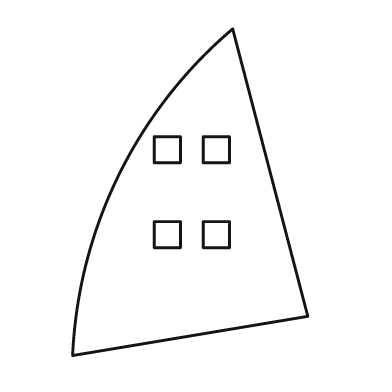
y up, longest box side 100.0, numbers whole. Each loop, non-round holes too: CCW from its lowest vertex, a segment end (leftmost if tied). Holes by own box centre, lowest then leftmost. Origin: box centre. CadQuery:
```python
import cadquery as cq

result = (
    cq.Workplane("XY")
    .moveTo(-36.0, -50.0)
    .lineTo(36.0, -38.0)
    .lineTo(13.0, 50.0)
    .threePointArc((-22.0, 5.0), (-36.0, -50.0))
    .close()
    .moveTo(-11.0, -17.0)
    .lineTo(-3.0, -17.0)
    .lineTo(-3.0, -9.0)
    .lineTo(-11.0, -9.0)
    .close()
    .moveTo(4.0, -17.0)
    .lineTo(12.0, -17.0)
    .lineTo(12.0, -9.0)
    .lineTo(4.0, -9.0)
    .close()
    .moveTo(-11.0, 9.0)
    .lineTo(-3.0, 9.0)
    .lineTo(-3.0, 17.0)
    .lineTo(-11.0, 17.0)
    .close()
    .moveTo(4.0, 9.0)
    .lineTo(12.0, 9.0)
    .lineTo(12.0, 17.0)
    .lineTo(4.0, 17.0)
    .close()
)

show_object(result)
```